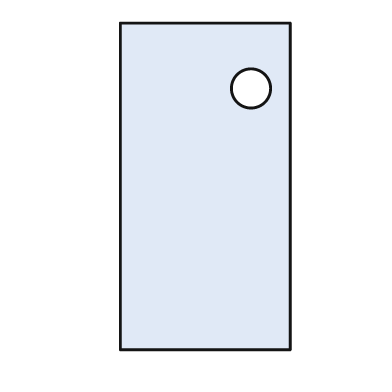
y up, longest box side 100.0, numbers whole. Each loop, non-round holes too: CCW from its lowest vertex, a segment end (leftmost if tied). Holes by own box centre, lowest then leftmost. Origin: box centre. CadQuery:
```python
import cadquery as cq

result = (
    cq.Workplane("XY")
    .moveTo(-26.0, -50.0)
    .lineTo(26.0, -50.0)
    .lineTo(26.0, 50.0)
    .lineTo(-26.0, 50.0)
    .close()
    .moveTo(14.0, 30.0)
    .circle(6.0)
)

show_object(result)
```